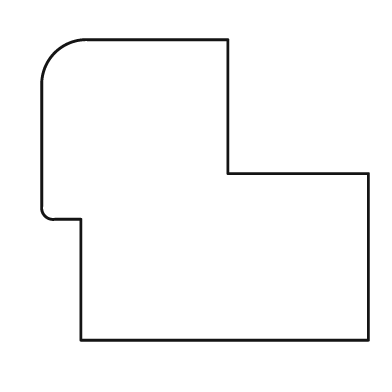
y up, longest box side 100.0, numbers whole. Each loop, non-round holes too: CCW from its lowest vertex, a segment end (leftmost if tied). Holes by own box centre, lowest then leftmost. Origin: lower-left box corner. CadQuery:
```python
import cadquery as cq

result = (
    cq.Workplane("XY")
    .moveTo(12.0, 0.0)
    .lineTo(100.0, 0.0)
    .lineTo(100.0, 51.0)
    .lineTo(57.0, 51.0)
    .lineTo(57.0, 92.0)
    .lineTo(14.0, 92.0)
    .threePointArc((4.0, 88.0), (0.0, 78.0))
    .lineTo(0.0, 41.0)
    .threePointArc((1.0, 38.0), (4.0, 37.0))
    .lineTo(12.0, 37.0)
    .close()
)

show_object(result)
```